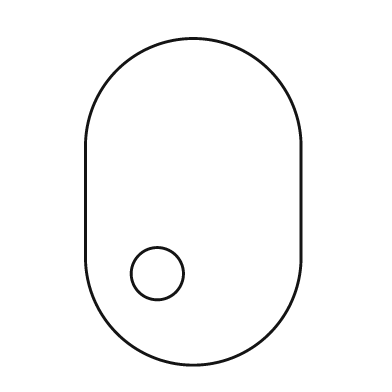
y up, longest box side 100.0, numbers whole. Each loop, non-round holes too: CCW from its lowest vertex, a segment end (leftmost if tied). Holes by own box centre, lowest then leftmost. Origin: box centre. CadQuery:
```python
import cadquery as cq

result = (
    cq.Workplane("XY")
    .moveTo(-33.0, -17.0)
    .threePointArc((0.0, -50.0), (33.0, -17.0))
    .lineTo(33.0, 17.0)
    .threePointArc((0.0, 50.0), (-33.0, 17.0))
    .close()
    .moveTo(-11.0, -22.0)
    .circle(8.0)
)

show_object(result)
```